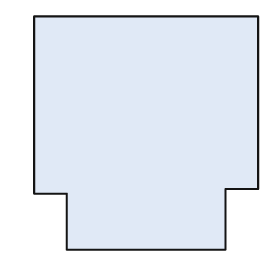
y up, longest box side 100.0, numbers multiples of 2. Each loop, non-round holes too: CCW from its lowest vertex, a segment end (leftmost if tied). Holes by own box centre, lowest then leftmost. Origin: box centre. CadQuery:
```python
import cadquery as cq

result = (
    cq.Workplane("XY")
    .moveTo(-34.0, -50.0)
    .lineTo(34.0, -50.0)
    .lineTo(34.0, -24.0)
    .lineTo(48.0, -24.0)
    .lineTo(48.0, 50.0)
    .lineTo(-48.0, 50.0)
    .lineTo(-48.0, -26.0)
    .lineTo(-34.0, -26.0)
    .close()
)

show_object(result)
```